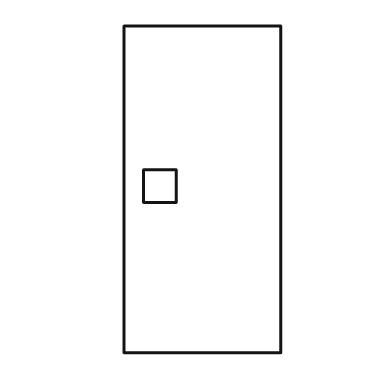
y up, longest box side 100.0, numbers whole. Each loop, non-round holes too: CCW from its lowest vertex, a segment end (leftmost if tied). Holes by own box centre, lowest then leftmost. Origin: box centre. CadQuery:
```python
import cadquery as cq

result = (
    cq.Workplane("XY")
    .moveTo(-24.0, -50.0)
    .lineTo(24.0, -50.0)
    .lineTo(24.0, 50.0)
    .lineTo(-24.0, 50.0)
    .close()
    .moveTo(-18.0, -4.0)
    .lineTo(-8.0, -4.0)
    .lineTo(-8.0, 6.0)
    .lineTo(-18.0, 6.0)
    .close()
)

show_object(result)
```